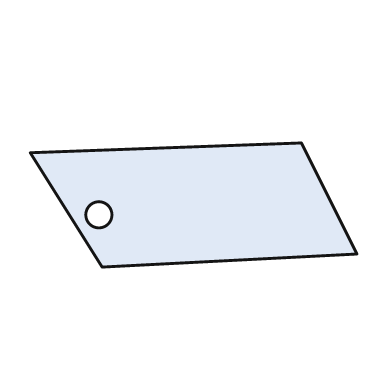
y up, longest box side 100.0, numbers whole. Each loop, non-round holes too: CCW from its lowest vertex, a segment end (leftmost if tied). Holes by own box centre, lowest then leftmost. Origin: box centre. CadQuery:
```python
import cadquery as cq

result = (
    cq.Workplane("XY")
    .moveTo(-28.0, -19.0)
    .lineTo(50.0, -15.0)
    .lineTo(33.0, 19.0)
    .lineTo(-50.0, 16.0)
    .close()
    .moveTo(-29.0, -3.0)
    .circle(4.0)
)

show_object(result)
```